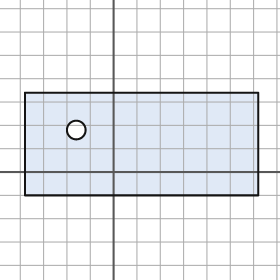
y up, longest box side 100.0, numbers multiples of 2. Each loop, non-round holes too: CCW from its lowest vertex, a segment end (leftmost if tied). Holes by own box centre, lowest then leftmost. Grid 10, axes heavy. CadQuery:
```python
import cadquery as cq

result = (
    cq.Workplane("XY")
    .moveTo(-38.0, -10.0)
    .lineTo(62.0, -10.0)
    .lineTo(62.0, 34.0)
    .lineTo(-38.0, 34.0)
    .close()
    .moveTo(-16.0, 18.0)
    .circle(4.0)
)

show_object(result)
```